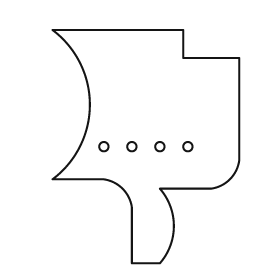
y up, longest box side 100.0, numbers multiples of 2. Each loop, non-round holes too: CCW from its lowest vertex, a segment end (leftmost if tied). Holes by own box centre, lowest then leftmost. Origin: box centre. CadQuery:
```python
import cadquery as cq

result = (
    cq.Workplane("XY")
    .moveTo(-6.0, -50.0)
    .lineTo(6.0, -50.0)
    .threePointArc((12.0, -34.0), (6.0, -18.0))
    .lineTo(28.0, -18.0)
    .threePointArc((36.0, -14.0), (40.0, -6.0))
    .lineTo(40.0, 38.0)
    .lineTo(16.0, 38.0)
    .lineTo(16.0, 50.0)
    .lineTo(-40.0, 50.0)
    .threePointArc((-24.0, 18.0), (-40.0, -14.0))
    .lineTo(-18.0, -14.0)
    .threePointArc((-10.0, -18.0), (-6.0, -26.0))
    .close()
    .moveTo(-18.0, 0.0)
    .circle(2.0)
    .moveTo(-6.0, 0.0)
    .circle(2.0)
    .moveTo(6.0, 0.0)
    .circle(2.0)
    .moveTo(18.0, 0.0)
    .circle(2.0)
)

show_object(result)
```